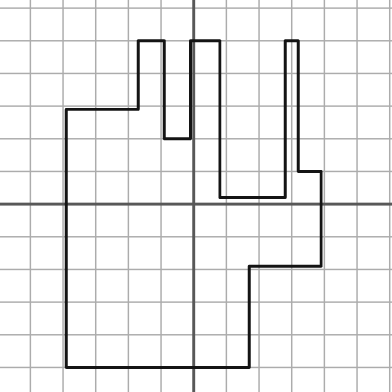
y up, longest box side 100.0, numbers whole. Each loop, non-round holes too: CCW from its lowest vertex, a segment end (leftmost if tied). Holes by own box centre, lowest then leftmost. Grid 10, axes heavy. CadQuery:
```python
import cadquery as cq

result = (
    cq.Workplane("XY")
    .moveTo(-39.0, -50.0)
    .lineTo(17.0, -50.0)
    .lineTo(17.0, -19.0)
    .lineTo(39.0, -19.0)
    .lineTo(39.0, 10.0)
    .lineTo(32.0, 10.0)
    .lineTo(32.0, 50.0)
    .lineTo(28.0, 50.0)
    .lineTo(28.0, 2.0)
    .lineTo(8.0, 2.0)
    .lineTo(8.0, 50.0)
    .lineTo(-1.0, 50.0)
    .lineTo(-1.0, 20.0)
    .lineTo(-9.0, 20.0)
    .lineTo(-9.0, 50.0)
    .lineTo(-17.0, 50.0)
    .lineTo(-17.0, 29.0)
    .lineTo(-39.0, 29.0)
    .close()
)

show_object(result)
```